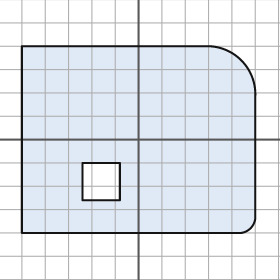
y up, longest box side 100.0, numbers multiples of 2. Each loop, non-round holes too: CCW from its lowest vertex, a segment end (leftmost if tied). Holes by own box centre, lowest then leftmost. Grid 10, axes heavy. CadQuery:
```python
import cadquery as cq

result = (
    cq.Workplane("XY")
    .moveTo(-50.0, -40.0)
    .lineTo(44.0, -40.0)
    .threePointArc((48.0, -38.0), (50.0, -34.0))
    .lineTo(50.0, 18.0)
    .threePointArc((44.0, 34.0), (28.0, 40.0))
    .lineTo(-50.0, 40.0)
    .close()
    .moveTo(-24.0, -26.0)
    .lineTo(-8.0, -26.0)
    .lineTo(-8.0, -10.0)
    .lineTo(-24.0, -10.0)
    .close()
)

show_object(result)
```